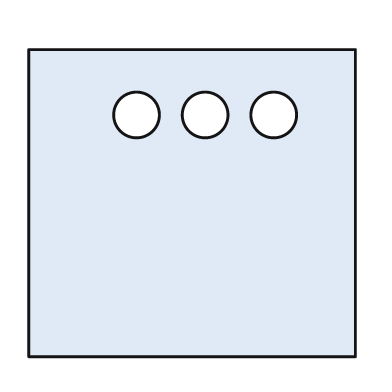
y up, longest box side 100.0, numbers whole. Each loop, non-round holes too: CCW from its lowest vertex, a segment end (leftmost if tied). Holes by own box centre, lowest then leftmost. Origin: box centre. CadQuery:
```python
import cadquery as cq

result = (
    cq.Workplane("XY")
    .moveTo(-50.0, -47.0)
    .lineTo(50.0, -47.0)
    .lineTo(50.0, 47.0)
    .lineTo(-50.0, 47.0)
    .close()
    .moveTo(-17.0, 27.0)
    .circle(7.0)
    .moveTo(4.0, 27.0)
    .circle(7.0)
    .moveTo(25.0, 27.0)
    .circle(7.0)
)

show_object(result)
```